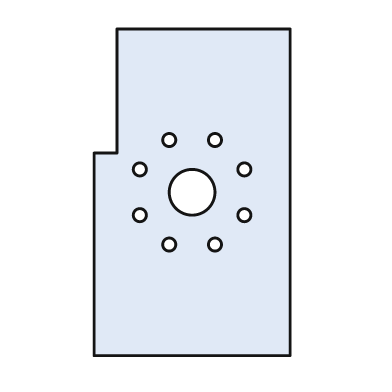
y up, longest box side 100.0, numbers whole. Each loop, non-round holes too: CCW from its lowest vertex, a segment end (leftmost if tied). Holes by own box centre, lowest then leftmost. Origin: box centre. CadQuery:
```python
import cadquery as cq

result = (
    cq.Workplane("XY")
    .moveTo(-30.0, -50.0)
    .lineTo(30.0, -50.0)
    .lineTo(30.0, 50.0)
    .lineTo(-23.0, 50.0)
    .lineTo(-23.0, 12.0)
    .lineTo(-30.0, 12.0)
    .close()
    .moveTo(-7.0, -16.0)
    .circle(2.0)
    .moveTo(7.0, -16.0)
    .circle(2.0)
    .moveTo(-16.0, -7.0)
    .circle(2.0)
    .moveTo(16.0, -7.0)
    .circle(2.0)
    .moveTo(0.0, 0.0)
    .circle(7.0)
    .moveTo(-16.0, 7.0)
    .circle(2.0)
    .moveTo(16.0, 7.0)
    .circle(2.0)
    .moveTo(-7.0, 16.0)
    .circle(2.0)
    .moveTo(7.0, 16.0)
    .circle(2.0)
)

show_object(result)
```